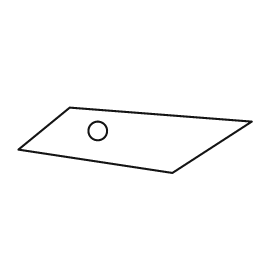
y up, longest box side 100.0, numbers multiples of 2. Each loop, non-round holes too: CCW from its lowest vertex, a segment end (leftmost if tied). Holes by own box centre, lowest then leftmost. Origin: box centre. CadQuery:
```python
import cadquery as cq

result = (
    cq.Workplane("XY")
    .moveTo(16.0, -14.0)
    .lineTo(50.0, 8.0)
    .lineTo(-28.0, 14.0)
    .lineTo(-50.0, -4.0)
    .close()
    .moveTo(-16.0, 4.0)
    .circle(4.0)
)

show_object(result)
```